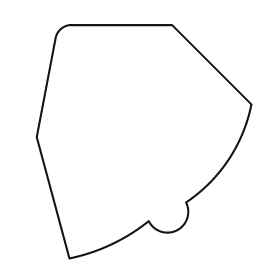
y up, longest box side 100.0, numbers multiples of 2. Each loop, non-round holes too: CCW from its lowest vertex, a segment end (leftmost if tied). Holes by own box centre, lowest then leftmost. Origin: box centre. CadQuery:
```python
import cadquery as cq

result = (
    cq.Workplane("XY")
    .moveTo(-32.0, -50.0)
    .threePointArc((-14.0, -44.0), (2.0, -34.0))
    .threePointArc((14.0, -38.0), (18.0, -26.0))
    .threePointArc((36.0, -8.0), (46.0, 16.0))
    .lineTo(12.0, 50.0)
    .lineTo(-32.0, 50.0)
    .threePointArc((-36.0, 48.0), (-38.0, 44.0))
    .lineTo(-46.0, 2.0)
    .close()
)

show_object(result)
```